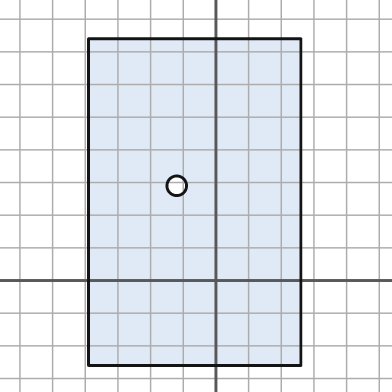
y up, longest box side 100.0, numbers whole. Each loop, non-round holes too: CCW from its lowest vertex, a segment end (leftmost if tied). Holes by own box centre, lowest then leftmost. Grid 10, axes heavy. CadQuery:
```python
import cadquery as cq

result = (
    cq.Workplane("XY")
    .moveTo(-39.0, -26.0)
    .lineTo(26.0, -26.0)
    .lineTo(26.0, 74.0)
    .lineTo(-39.0, 74.0)
    .close()
    .moveTo(-12.0, 29.0)
    .circle(3.0)
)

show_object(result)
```